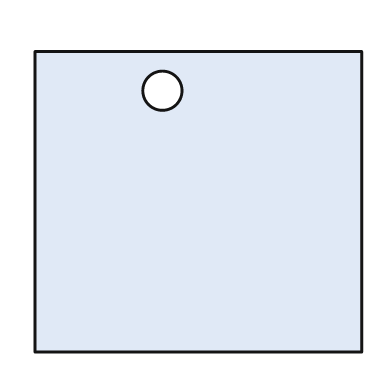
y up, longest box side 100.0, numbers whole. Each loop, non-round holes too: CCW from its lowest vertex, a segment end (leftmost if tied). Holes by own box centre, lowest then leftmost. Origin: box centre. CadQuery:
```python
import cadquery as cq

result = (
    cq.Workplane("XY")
    .moveTo(-50.0, -46.0)
    .lineTo(50.0, -46.0)
    .lineTo(50.0, 46.0)
    .lineTo(-50.0, 46.0)
    .close()
    .moveTo(-11.0, 34.0)
    .circle(6.0)
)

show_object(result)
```